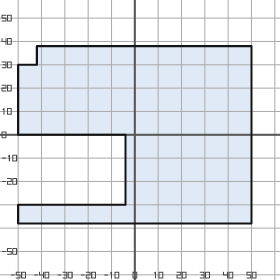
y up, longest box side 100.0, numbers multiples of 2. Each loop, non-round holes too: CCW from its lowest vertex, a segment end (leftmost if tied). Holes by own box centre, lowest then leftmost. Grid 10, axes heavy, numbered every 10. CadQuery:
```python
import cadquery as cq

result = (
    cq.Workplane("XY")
    .moveTo(-50.0, -38.0)
    .lineTo(50.0, -38.0)
    .lineTo(50.0, 38.0)
    .lineTo(-42.0, 38.0)
    .lineTo(-42.0, 30.0)
    .lineTo(-50.0, 30.0)
    .lineTo(-50.0, 0.0)
    .lineTo(-4.0, 0.0)
    .lineTo(-4.0, -30.0)
    .lineTo(-50.0, -30.0)
    .close()
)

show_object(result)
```